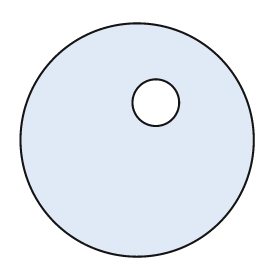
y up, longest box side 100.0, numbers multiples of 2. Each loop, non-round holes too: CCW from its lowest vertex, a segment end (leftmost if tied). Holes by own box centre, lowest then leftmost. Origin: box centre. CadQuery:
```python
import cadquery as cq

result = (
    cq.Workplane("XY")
    .moveTo(0.0, 0.0)
    .circle(50.0)
    .moveTo(8.0, 16.0)
    .circle(10.0)
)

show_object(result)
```